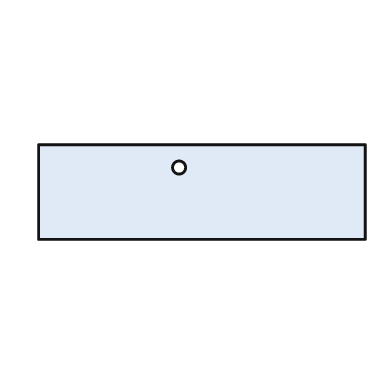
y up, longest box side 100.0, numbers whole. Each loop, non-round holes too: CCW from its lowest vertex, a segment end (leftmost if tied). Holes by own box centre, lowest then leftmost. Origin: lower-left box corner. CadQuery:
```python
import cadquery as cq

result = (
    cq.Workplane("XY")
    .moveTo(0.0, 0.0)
    .lineTo(100.0, 0.0)
    .lineTo(100.0, 29.0)
    .lineTo(0.0, 29.0)
    .close()
    .moveTo(43.0, 22.0)
    .circle(2.0)
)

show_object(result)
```